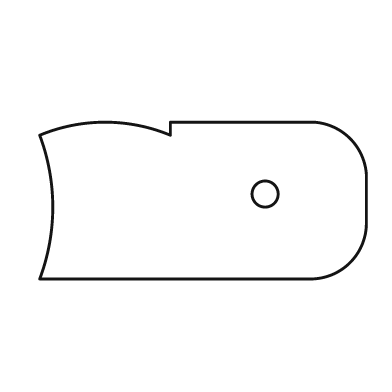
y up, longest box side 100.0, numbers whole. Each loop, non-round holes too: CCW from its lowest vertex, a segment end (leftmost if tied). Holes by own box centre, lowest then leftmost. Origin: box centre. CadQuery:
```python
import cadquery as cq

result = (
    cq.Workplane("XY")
    .moveTo(-50.0, -24.0)
    .lineTo(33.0, -24.0)
    .threePointArc((45.0, -19.0), (50.0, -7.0))
    .lineTo(50.0, 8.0)
    .threePointArc((45.0, 19.0), (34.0, 24.0))
    .lineTo(-10.0, 24.0)
    .lineTo(-10.0, 20.0)
    .threePointArc((-30.0, 24.0), (-50.0, 20.0))
    .threePointArc((-46.0, -2.0), (-50.0, -24.0))
    .close()
    .moveTo(19.0, 2.0)
    .circle(4.0)
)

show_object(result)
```